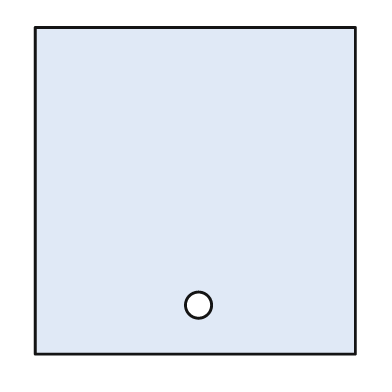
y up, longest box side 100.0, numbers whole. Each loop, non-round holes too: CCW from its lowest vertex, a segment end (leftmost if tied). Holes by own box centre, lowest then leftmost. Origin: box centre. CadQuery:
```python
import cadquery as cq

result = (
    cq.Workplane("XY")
    .moveTo(-49.0, -50.0)
    .lineTo(49.0, -50.0)
    .lineTo(49.0, 50.0)
    .lineTo(-49.0, 50.0)
    .close()
    .moveTo(1.0, -35.0)
    .circle(4.0)
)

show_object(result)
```